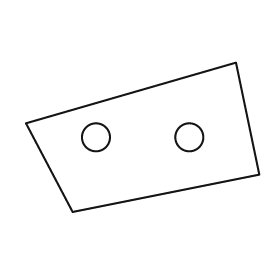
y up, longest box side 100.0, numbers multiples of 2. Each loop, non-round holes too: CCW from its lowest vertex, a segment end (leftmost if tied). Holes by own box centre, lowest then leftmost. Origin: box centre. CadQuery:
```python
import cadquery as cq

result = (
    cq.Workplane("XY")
    .moveTo(-30.0, -32.0)
    .lineTo(50.0, -16.0)
    .lineTo(40.0, 32.0)
    .lineTo(-50.0, 6.0)
    .close()
    .moveTo(-20.0, 0.0)
    .circle(6.0)
    .moveTo(20.0, 0.0)
    .circle(6.0)
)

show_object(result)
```